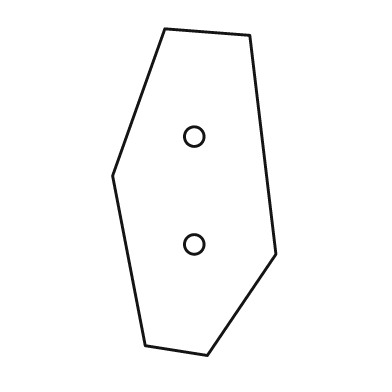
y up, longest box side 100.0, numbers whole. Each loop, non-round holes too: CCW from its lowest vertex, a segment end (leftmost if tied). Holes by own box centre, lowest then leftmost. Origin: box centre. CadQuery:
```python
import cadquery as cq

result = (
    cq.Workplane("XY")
    .moveTo(4.0, -50.0)
    .lineTo(25.0, -19.0)
    .lineTo(17.0, 48.0)
    .lineTo(-9.0, 50.0)
    .lineTo(-25.0, 5.0)
    .lineTo(-15.0, -47.0)
    .close()
    .moveTo(0.0, -16.0)
    .circle(3.0)
    .moveTo(0.0, 17.0)
    .circle(3.0)
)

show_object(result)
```